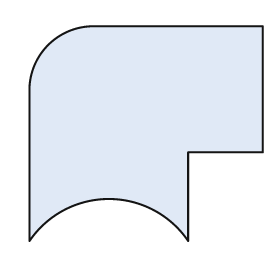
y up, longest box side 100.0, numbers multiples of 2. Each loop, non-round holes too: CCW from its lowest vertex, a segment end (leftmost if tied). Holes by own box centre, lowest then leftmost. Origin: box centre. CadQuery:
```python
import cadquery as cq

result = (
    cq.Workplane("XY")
    .moveTo(-50.0, -46.0)
    .threePointArc((-16.0, -28.0), (18.0, -46.0))
    .lineTo(18.0, -8.0)
    .lineTo(50.0, -8.0)
    .lineTo(50.0, 46.0)
    .lineTo(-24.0, 46.0)
    .threePointArc((-42.0, 38.0), (-50.0, 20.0))
    .close()
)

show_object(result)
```